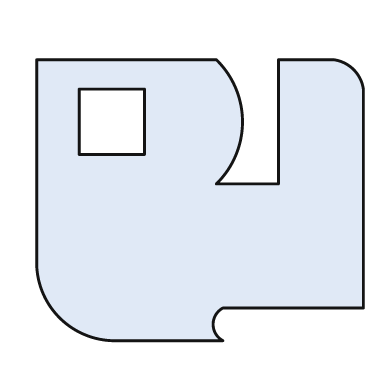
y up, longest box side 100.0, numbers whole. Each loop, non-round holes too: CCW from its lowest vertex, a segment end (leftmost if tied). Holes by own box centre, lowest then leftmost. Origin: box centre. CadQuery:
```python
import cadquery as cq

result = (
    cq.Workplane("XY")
    .moveTo(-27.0, -43.0)
    .lineTo(7.0, -43.0)
    .threePointArc((4.0, -38.0), (7.0, -33.0))
    .lineTo(50.0, -33.0)
    .lineTo(50.0, 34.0)
    .threePointArc((47.0, 40.0), (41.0, 43.0))
    .lineTo(24.0, 43.0)
    .lineTo(24.0, 5.0)
    .lineTo(5.0, 5.0)
    .threePointArc((13.0, 24.0), (5.0, 43.0))
    .lineTo(-50.0, 43.0)
    .lineTo(-50.0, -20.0)
    .threePointArc((-43.0, -36.0), (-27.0, -43.0))
    .close()
    .moveTo(-37.0, 14.0)
    .lineTo(-17.0, 14.0)
    .lineTo(-17.0, 34.0)
    .lineTo(-37.0, 34.0)
    .close()
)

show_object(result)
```